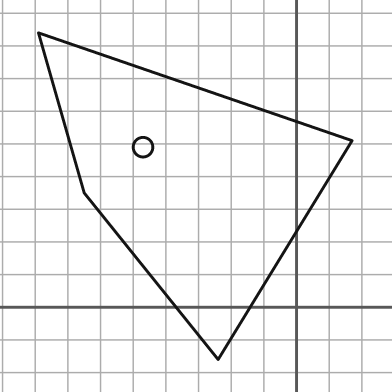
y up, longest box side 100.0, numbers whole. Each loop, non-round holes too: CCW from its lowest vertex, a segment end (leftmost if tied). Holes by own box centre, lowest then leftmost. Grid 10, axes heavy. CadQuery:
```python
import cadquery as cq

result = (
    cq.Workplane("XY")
    .moveTo(-24.0, -16.0)
    .lineTo(17.0, 51.0)
    .lineTo(-79.0, 84.0)
    .lineTo(-65.0, 35.0)
    .close()
    .moveTo(-47.0, 49.0)
    .circle(3.0)
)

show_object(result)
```